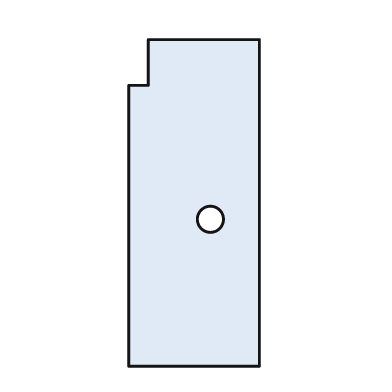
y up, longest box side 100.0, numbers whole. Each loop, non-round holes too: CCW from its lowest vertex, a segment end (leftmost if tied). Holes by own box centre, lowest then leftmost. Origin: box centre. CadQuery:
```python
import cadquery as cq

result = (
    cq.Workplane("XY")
    .moveTo(-20.0, -50.0)
    .lineTo(20.0, -50.0)
    .lineTo(20.0, 50.0)
    .lineTo(-14.0, 50.0)
    .lineTo(-14.0, 36.0)
    .lineTo(-20.0, 36.0)
    .close()
    .moveTo(5.0, -5.0)
    .circle(4.0)
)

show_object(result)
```